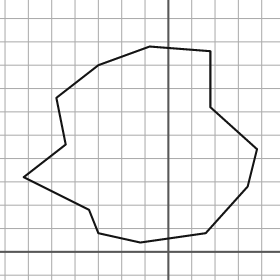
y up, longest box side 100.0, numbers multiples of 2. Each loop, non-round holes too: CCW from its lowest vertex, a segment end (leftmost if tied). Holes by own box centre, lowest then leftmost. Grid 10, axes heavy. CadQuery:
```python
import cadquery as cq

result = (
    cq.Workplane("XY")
    .moveTo(-12.0, 4.0)
    .lineTo(16.0, 8.0)
    .lineTo(34.0, 28.0)
    .lineTo(38.0, 44.0)
    .lineTo(18.0, 62.0)
    .lineTo(18.0, 86.0)
    .lineTo(-8.0, 88.0)
    .lineTo(-30.0, 80.0)
    .lineTo(-48.0, 66.0)
    .lineTo(-44.0, 46.0)
    .lineTo(-62.0, 32.0)
    .lineTo(-34.0, 18.0)
    .lineTo(-30.0, 8.0)
    .close()
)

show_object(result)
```